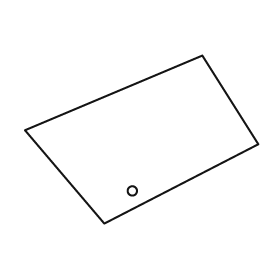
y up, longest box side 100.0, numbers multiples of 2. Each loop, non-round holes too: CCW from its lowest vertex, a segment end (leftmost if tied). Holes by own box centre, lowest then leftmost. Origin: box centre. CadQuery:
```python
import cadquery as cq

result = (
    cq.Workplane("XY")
    .moveTo(-16.0, -36.0)
    .lineTo(50.0, -2.0)
    .lineTo(26.0, 36.0)
    .lineTo(-50.0, 4.0)
    .close()
    .moveTo(-4.0, -22.0)
    .circle(2.0)
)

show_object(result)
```